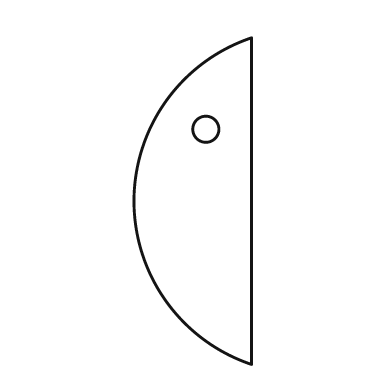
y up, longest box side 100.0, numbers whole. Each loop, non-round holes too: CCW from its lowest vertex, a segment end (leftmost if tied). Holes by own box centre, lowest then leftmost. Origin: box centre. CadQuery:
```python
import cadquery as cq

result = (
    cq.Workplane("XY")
    .moveTo(18.0, -50.0)
    .lineTo(18.0, 50.0)
    .threePointArc((-18.0, 0.0), (18.0, -50.0))
    .close()
    .moveTo(4.0, 22.0)
    .circle(4.0)
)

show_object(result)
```